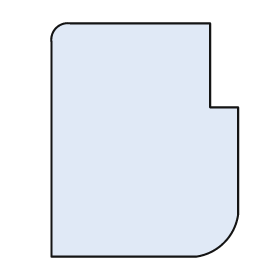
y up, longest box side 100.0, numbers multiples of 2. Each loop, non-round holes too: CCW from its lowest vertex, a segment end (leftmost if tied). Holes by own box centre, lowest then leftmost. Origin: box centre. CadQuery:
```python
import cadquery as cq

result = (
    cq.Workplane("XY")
    .moveTo(-40.0, -50.0)
    .lineTo(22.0, -50.0)
    .threePointArc((34.0, -44.0), (40.0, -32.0))
    .lineTo(40.0, 14.0)
    .lineTo(28.0, 14.0)
    .lineTo(28.0, 50.0)
    .lineTo(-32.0, 50.0)
    .threePointArc((-38.0, 48.0), (-40.0, 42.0))
    .close()
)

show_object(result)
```